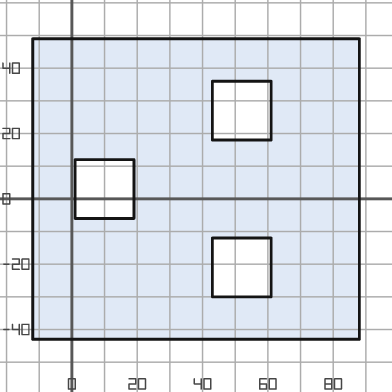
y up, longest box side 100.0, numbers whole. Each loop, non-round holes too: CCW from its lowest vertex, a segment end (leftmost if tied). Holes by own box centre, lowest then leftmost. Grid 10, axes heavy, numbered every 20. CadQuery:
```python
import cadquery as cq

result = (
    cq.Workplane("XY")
    .moveTo(-12.0, -43.0)
    .lineTo(88.0, -43.0)
    .lineTo(88.0, 49.0)
    .lineTo(-12.0, 49.0)
    .close()
    .moveTo(43.0, -30.0)
    .lineTo(61.0, -30.0)
    .lineTo(61.0, -12.0)
    .lineTo(43.0, -12.0)
    .close()
    .moveTo(1.0, -6.0)
    .lineTo(19.0, -6.0)
    .lineTo(19.0, 12.0)
    .lineTo(1.0, 12.0)
    .close()
    .moveTo(43.0, 18.0)
    .lineTo(61.0, 18.0)
    .lineTo(61.0, 36.0)
    .lineTo(43.0, 36.0)
    .close()
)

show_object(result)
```